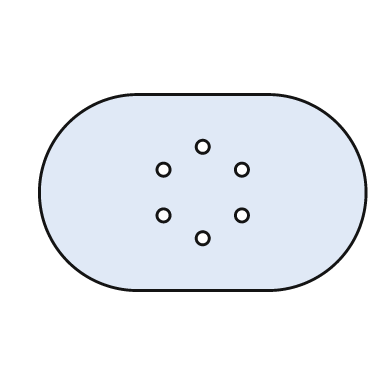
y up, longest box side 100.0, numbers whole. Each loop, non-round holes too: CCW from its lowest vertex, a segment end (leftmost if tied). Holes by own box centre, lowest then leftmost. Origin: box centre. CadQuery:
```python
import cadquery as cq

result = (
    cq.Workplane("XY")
    .moveTo(-20.0, -30.0)
    .lineTo(20.0, -30.0)
    .threePointArc((50.0, 0.0), (20.0, 30.0))
    .lineTo(-20.0, 30.0)
    .threePointArc((-50.0, 0.0), (-20.0, -30.0))
    .close()
    .moveTo(0.0, -14.0)
    .circle(2.0)
    .moveTo(-12.0, -7.0)
    .circle(2.0)
    .moveTo(12.0, -7.0)
    .circle(2.0)
    .moveTo(-12.0, 7.0)
    .circle(2.0)
    .moveTo(12.0, 7.0)
    .circle(2.0)
    .moveTo(0.0, 14.0)
    .circle(2.0)
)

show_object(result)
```